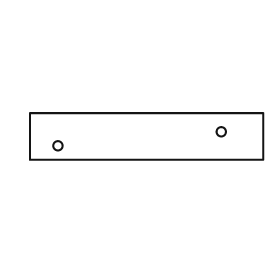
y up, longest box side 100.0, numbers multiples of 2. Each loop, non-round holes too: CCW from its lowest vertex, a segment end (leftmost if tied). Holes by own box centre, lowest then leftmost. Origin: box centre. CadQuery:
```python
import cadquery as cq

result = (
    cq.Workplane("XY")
    .moveTo(-50.0, -10.0)
    .lineTo(50.0, -10.0)
    .lineTo(50.0, 10.0)
    .lineTo(-50.0, 10.0)
    .close()
    .moveTo(-38.0, -4.0)
    .circle(2.0)
    .moveTo(32.0, 2.0)
    .circle(2.0)
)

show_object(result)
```